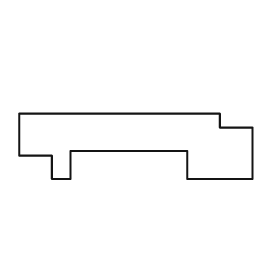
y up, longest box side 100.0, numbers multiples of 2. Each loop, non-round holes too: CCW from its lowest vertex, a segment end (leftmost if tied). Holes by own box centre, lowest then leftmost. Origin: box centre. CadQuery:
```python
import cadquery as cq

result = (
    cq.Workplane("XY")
    .moveTo(-36.0, -14.0)
    .lineTo(-28.0, -14.0)
    .lineTo(-28.0, -2.0)
    .lineTo(22.0, -2.0)
    .lineTo(22.0, -14.0)
    .lineTo(50.0, -14.0)
    .lineTo(50.0, 8.0)
    .lineTo(36.0, 8.0)
    .lineTo(36.0, 14.0)
    .lineTo(-50.0, 14.0)
    .lineTo(-50.0, -4.0)
    .lineTo(-36.0, -4.0)
    .close()
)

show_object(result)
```